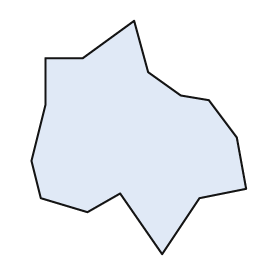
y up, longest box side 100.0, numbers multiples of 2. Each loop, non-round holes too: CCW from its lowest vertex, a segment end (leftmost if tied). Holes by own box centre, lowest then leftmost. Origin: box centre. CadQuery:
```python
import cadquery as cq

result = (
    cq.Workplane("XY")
    .moveTo(10.0, -50.0)
    .lineTo(26.0, -26.0)
    .lineTo(46.0, -22.0)
    .lineTo(42.0, 0.0)
    .lineTo(30.0, 16.0)
    .lineTo(18.0, 18.0)
    .lineTo(4.0, 28.0)
    .lineTo(-2.0, 50.0)
    .lineTo(-24.0, 34.0)
    .lineTo(-40.0, 34.0)
    .lineTo(-40.0, 14.0)
    .lineTo(-46.0, -10.0)
    .lineTo(-42.0, -26.0)
    .lineTo(-22.0, -32.0)
    .lineTo(-8.0, -24.0)
    .close()
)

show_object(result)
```